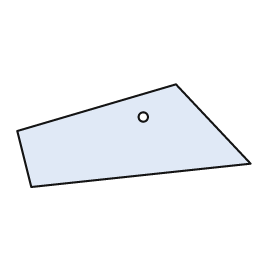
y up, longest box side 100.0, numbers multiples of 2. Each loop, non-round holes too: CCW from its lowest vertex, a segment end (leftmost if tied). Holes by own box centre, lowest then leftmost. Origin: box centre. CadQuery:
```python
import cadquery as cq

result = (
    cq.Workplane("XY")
    .moveTo(-44.0, -22.0)
    .lineTo(50.0, -12.0)
    .lineTo(18.0, 22.0)
    .lineTo(-50.0, 2.0)
    .close()
    .moveTo(4.0, 8.0)
    .circle(2.0)
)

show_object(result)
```